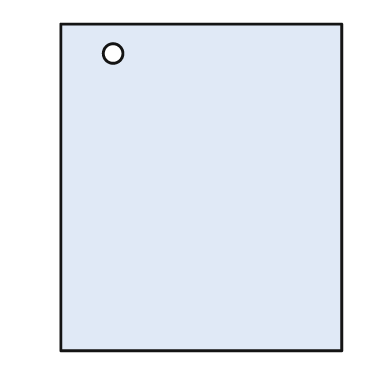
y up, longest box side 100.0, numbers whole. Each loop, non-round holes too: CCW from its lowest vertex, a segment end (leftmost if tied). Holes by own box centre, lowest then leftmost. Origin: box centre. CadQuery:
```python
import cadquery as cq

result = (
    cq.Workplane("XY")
    .moveTo(-43.0, -50.0)
    .lineTo(43.0, -50.0)
    .lineTo(43.0, 50.0)
    .lineTo(-43.0, 50.0)
    .close()
    .moveTo(-27.0, 41.0)
    .circle(3.0)
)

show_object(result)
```